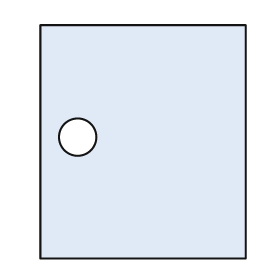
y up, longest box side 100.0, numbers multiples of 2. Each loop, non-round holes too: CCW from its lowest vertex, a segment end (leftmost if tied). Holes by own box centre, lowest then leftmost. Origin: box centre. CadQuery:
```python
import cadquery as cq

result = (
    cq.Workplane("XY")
    .moveTo(-44.0, -50.0)
    .lineTo(44.0, -50.0)
    .lineTo(44.0, 50.0)
    .lineTo(-44.0, 50.0)
    .close()
    .moveTo(-28.0, 2.0)
    .circle(8.0)
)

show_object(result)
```